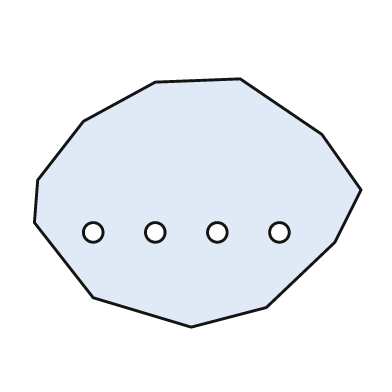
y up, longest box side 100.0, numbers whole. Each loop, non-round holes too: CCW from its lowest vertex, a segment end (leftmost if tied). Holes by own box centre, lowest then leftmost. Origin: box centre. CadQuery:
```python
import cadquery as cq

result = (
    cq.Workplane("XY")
    .moveTo(-2.0, -38.0)
    .lineTo(21.0, -32.0)
    .lineTo(42.0, -12.0)
    .lineTo(50.0, 4.0)
    .lineTo(38.0, 21.0)
    .lineTo(13.0, 38.0)
    .lineTo(-13.0, 37.0)
    .lineTo(-35.0, 25.0)
    .lineTo(-49.0, 7.0)
    .lineTo(-50.0, -6.0)
    .lineTo(-32.0, -29.0)
    .close()
    .moveTo(-32.0, -9.0)
    .circle(3.0)
    .moveTo(-13.0, -9.0)
    .circle(3.0)
    .moveTo(6.0, -9.0)
    .circle(3.0)
    .moveTo(25.0, -9.0)
    .circle(3.0)
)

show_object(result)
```